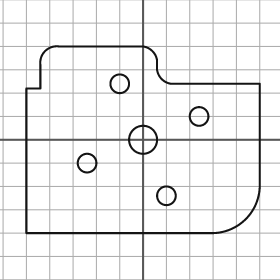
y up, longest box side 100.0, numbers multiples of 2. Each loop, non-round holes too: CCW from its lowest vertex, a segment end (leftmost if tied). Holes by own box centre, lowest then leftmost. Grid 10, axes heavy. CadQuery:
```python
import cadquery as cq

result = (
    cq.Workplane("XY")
    .moveTo(-50.0, -40.0)
    .lineTo(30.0, -40.0)
    .threePointArc((44.0, -34.0), (50.0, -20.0))
    .lineTo(50.0, 24.0)
    .lineTo(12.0, 24.0)
    .threePointArc((8.0, 26.0), (6.0, 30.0))
    .lineTo(6.0, 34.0)
    .threePointArc((4.0, 38.0), (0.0, 40.0))
    .lineTo(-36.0, 40.0)
    .threePointArc((-42.0, 38.0), (-44.0, 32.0))
    .lineTo(-44.0, 22.0)
    .lineTo(-50.0, 22.0)
    .close()
    .moveTo(10.0, -24.0)
    .circle(4.0)
    .moveTo(-24.0, -10.0)
    .circle(4.0)
    .moveTo(0.0, 0.0)
    .circle(6.0)
    .moveTo(24.0, 10.0)
    .circle(4.0)
    .moveTo(-10.0, 24.0)
    .circle(4.0)
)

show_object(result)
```